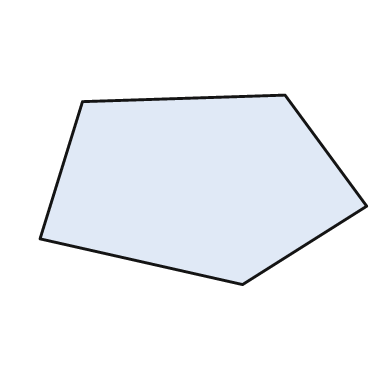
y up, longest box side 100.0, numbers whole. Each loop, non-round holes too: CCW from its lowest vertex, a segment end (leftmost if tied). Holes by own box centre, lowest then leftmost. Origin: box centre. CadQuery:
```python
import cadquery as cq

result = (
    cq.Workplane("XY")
    .moveTo(12.0, -29.0)
    .lineTo(50.0, -5.0)
    .lineTo(25.0, 29.0)
    .lineTo(-37.0, 27.0)
    .lineTo(-50.0, -15.0)
    .close()
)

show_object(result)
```